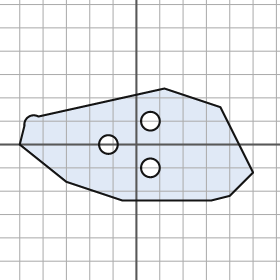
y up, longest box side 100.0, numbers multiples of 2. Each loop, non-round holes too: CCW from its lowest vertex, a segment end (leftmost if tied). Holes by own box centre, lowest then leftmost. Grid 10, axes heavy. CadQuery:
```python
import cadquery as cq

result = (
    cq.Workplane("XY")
    .moveTo(-6.0, -24.0)
    .lineTo(32.0, -24.0)
    .lineTo(40.0, -22.0)
    .lineTo(50.0, -12.0)
    .lineTo(36.0, 16.0)
    .lineTo(12.0, 24.0)
    .lineTo(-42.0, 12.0)
    .threePointArc((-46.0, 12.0), (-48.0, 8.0))
    .lineTo(-50.0, 0.0)
    .lineTo(-30.0, -16.0)
    .close()
    .moveTo(6.0, -10.0)
    .circle(4.0)
    .moveTo(-12.0, 0.0)
    .circle(4.0)
    .moveTo(6.0, 10.0)
    .circle(4.0)
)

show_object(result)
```